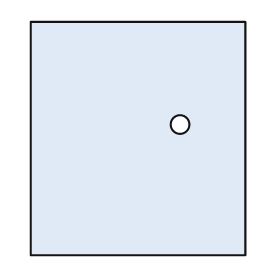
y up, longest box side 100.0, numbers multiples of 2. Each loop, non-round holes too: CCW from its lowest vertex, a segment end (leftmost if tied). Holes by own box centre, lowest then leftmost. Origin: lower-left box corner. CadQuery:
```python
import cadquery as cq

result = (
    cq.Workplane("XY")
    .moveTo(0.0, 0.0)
    .lineTo(92.0, 0.0)
    .lineTo(92.0, 100.0)
    .lineTo(0.0, 100.0)
    .close()
    .moveTo(64.0, 56.0)
    .circle(4.0)
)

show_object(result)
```